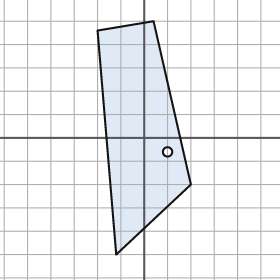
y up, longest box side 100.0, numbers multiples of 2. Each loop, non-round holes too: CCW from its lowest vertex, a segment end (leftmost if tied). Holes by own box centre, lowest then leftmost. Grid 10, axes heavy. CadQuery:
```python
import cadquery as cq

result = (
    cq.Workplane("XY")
    .moveTo(-12.0, -50.0)
    .lineTo(20.0, -20.0)
    .lineTo(4.0, 50.0)
    .lineTo(-20.0, 46.0)
    .close()
    .moveTo(10.0, -6.0)
    .circle(2.0)
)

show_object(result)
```